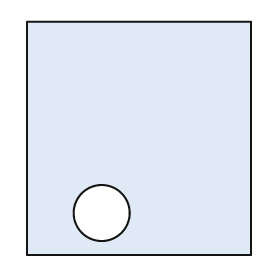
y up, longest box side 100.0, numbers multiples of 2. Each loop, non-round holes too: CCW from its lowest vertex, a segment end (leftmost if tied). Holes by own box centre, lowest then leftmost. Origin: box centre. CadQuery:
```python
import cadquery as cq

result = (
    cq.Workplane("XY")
    .moveTo(-48.0, -50.0)
    .lineTo(48.0, -50.0)
    .lineTo(48.0, 50.0)
    .lineTo(-48.0, 50.0)
    .close()
    .moveTo(-16.0, -32.0)
    .circle(12.0)
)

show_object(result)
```